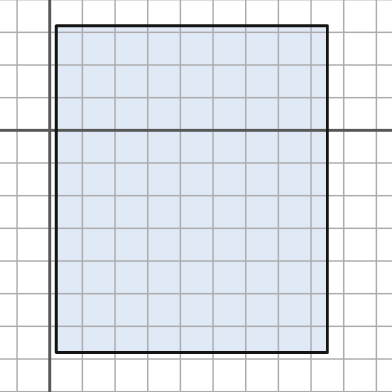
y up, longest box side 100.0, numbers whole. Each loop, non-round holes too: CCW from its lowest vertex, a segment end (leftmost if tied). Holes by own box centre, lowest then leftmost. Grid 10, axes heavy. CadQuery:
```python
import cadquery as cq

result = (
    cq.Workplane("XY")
    .moveTo(2.0, -68.0)
    .lineTo(85.0, -68.0)
    .lineTo(85.0, 32.0)
    .lineTo(2.0, 32.0)
    .close()
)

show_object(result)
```